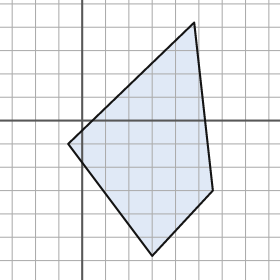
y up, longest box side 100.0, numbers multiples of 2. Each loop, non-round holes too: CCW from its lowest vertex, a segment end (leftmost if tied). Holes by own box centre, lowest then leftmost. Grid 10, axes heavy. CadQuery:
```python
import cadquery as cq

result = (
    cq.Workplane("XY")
    .moveTo(30.0, -58.0)
    .lineTo(56.0, -30.0)
    .lineTo(48.0, 42.0)
    .lineTo(-6.0, -10.0)
    .close()
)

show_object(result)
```